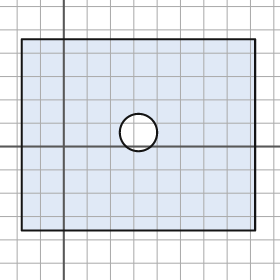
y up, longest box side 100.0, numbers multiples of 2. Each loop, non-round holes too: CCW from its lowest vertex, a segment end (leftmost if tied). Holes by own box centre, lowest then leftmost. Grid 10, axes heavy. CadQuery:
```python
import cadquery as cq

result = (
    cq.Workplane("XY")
    .moveTo(-18.0, -36.0)
    .lineTo(82.0, -36.0)
    .lineTo(82.0, 46.0)
    .lineTo(-18.0, 46.0)
    .close()
    .moveTo(32.0, 6.0)
    .circle(8.0)
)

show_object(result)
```